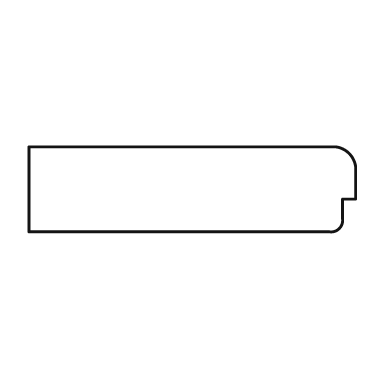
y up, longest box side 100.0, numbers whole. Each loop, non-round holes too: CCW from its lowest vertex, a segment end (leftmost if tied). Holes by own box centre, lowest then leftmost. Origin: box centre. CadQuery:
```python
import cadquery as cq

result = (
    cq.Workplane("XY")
    .moveTo(-50.0, -13.0)
    .lineTo(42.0, -13.0)
    .threePointArc((45.0, -12.0), (46.0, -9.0))
    .lineTo(46.0, -3.0)
    .lineTo(50.0, -3.0)
    .lineTo(50.0, 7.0)
    .threePointArc((48.0, 11.0), (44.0, 13.0))
    .lineTo(-50.0, 13.0)
    .close()
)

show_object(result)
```